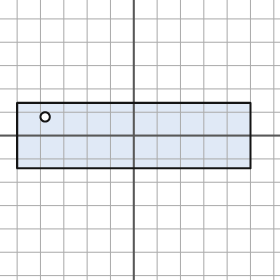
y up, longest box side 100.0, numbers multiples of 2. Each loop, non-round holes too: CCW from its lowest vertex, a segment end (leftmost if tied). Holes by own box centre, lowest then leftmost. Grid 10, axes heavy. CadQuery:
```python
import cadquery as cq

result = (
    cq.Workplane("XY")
    .moveTo(-50.0, -14.0)
    .lineTo(50.0, -14.0)
    .lineTo(50.0, 14.0)
    .lineTo(-50.0, 14.0)
    .close()
    .moveTo(-38.0, 8.0)
    .circle(2.0)
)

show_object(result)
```